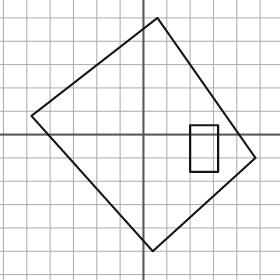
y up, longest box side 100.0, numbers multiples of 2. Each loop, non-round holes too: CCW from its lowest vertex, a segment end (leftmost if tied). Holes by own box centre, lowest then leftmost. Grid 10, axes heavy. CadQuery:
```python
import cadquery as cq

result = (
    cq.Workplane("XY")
    .moveTo(4.0, -50.0)
    .lineTo(48.0, -10.0)
    .lineTo(6.0, 50.0)
    .lineTo(-48.0, 8.0)
    .close()
    .moveTo(20.0, -16.0)
    .lineTo(32.0, -16.0)
    .lineTo(32.0, 4.0)
    .lineTo(20.0, 4.0)
    .close()
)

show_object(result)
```